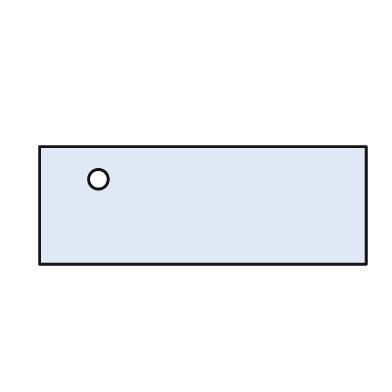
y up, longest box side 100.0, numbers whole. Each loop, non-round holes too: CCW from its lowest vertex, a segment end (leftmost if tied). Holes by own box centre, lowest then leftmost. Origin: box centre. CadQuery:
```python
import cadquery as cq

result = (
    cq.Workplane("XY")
    .moveTo(-50.0, -18.0)
    .lineTo(50.0, -18.0)
    .lineTo(50.0, 18.0)
    .lineTo(-50.0, 18.0)
    .close()
    .moveTo(-32.0, 8.0)
    .circle(3.0)
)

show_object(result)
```